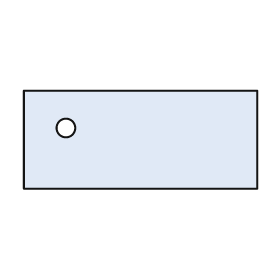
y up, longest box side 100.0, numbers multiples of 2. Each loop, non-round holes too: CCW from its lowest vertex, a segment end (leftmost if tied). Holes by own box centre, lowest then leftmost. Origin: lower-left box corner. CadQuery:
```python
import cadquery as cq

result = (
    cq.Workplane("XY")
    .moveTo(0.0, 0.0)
    .lineTo(100.0, 0.0)
    .lineTo(100.0, 42.0)
    .lineTo(0.0, 42.0)
    .close()
    .moveTo(18.0, 26.0)
    .circle(4.0)
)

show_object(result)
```